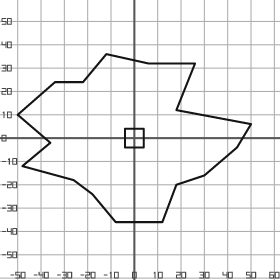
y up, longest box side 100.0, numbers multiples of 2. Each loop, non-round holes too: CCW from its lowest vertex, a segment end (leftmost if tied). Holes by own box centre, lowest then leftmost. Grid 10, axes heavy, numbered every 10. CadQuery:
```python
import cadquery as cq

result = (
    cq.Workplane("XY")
    .moveTo(-8.0, -36.0)
    .lineTo(12.0, -36.0)
    .lineTo(18.0, -20.0)
    .lineTo(30.0, -16.0)
    .lineTo(44.0, -4.0)
    .lineTo(50.0, 6.0)
    .lineTo(18.0, 12.0)
    .lineTo(26.0, 32.0)
    .lineTo(6.0, 32.0)
    .lineTo(-12.0, 36.0)
    .lineTo(-22.0, 24.0)
    .lineTo(-34.0, 24.0)
    .lineTo(-50.0, 10.0)
    .lineTo(-36.0, -2.0)
    .lineTo(-48.0, -12.0)
    .lineTo(-26.0, -18.0)
    .lineTo(-18.0, -24.0)
    .close()
    .moveTo(-4.0, -4.0)
    .lineTo(4.0, -4.0)
    .lineTo(4.0, 4.0)
    .lineTo(-4.0, 4.0)
    .close()
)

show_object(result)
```